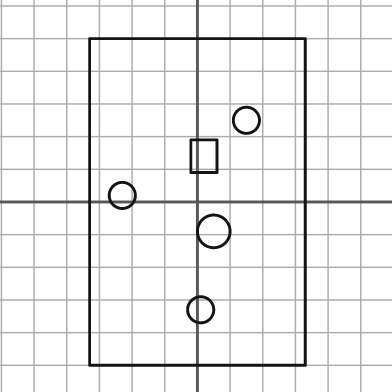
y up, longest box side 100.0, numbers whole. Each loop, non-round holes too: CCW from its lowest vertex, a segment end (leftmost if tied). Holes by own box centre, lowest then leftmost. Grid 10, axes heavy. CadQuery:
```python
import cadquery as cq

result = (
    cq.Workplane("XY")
    .moveTo(-33.0, -50.0)
    .lineTo(33.0, -50.0)
    .lineTo(33.0, 50.0)
    .lineTo(-33.0, 50.0)
    .close()
    .moveTo(1.0, -33.0)
    .circle(4.0)
    .moveTo(5.0, -9.0)
    .circle(5.0)
    .moveTo(-23.0, 2.0)
    .circle(4.0)
    .moveTo(-2.0, 9.0)
    .lineTo(6.0, 9.0)
    .lineTo(6.0, 19.0)
    .lineTo(-2.0, 19.0)
    .close()
    .moveTo(15.0, 25.0)
    .circle(4.0)
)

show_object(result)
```